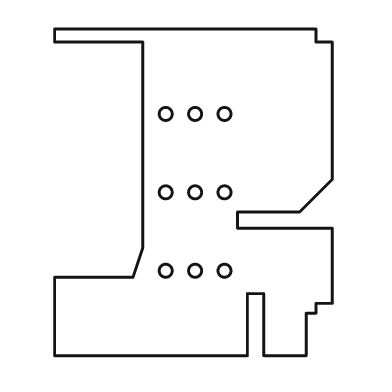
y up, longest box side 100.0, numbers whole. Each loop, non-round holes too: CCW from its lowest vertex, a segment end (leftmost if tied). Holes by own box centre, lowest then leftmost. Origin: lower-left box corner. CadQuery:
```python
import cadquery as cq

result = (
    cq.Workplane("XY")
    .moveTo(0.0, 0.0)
    .lineTo(59.0, 0.0)
    .lineTo(59.0, 19.0)
    .lineTo(64.0, 19.0)
    .lineTo(64.0, 0.0)
    .lineTo(77.0, 0.0)
    .lineTo(77.0, 13.0)
    .lineTo(80.0, 13.0)
    .lineTo(80.0, 16.0)
    .lineTo(85.0, 16.0)
    .lineTo(85.0, 39.0)
    .lineTo(56.0, 39.0)
    .lineTo(56.0, 44.0)
    .lineTo(75.0, 44.0)
    .lineTo(85.0, 54.0)
    .lineTo(85.0, 96.0)
    .lineTo(80.0, 96.0)
    .lineTo(80.0, 100.0)
    .lineTo(0.0, 100.0)
    .lineTo(0.0, 96.0)
    .lineTo(27.0, 96.0)
    .lineTo(27.0, 33.0)
    .lineTo(24.0, 24.0)
    .lineTo(0.0, 24.0)
    .close()
    .moveTo(34.0, 26.0)
    .circle(2.0)
    .moveTo(43.0, 26.0)
    .circle(2.0)
    .moveTo(52.0, 26.0)
    .circle(2.0)
    .moveTo(34.0, 50.0)
    .circle(2.0)
    .moveTo(43.0, 50.0)
    .circle(2.0)
    .moveTo(52.0, 50.0)
    .circle(2.0)
    .moveTo(34.0, 74.0)
    .circle(2.0)
    .moveTo(43.0, 74.0)
    .circle(2.0)
    .moveTo(52.0, 74.0)
    .circle(2.0)
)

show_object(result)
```